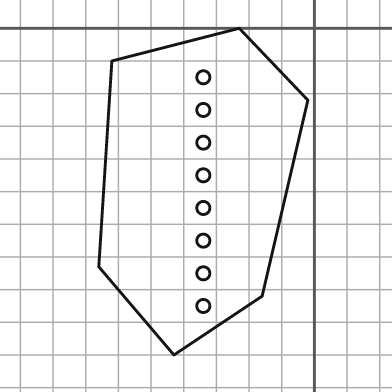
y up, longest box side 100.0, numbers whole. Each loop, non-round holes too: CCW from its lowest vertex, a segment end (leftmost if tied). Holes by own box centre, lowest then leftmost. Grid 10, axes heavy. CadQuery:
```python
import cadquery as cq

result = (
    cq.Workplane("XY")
    .moveTo(-43.0, -100.0)
    .lineTo(-16.0, -82.0)
    .lineTo(-2.0, -22.0)
    .lineTo(-23.0, 0.0)
    .lineTo(-62.0, -10.0)
    .lineTo(-66.0, -73.0)
    .close()
    .moveTo(-34.0, -85.0)
    .circle(2.0)
    .moveTo(-34.0, -75.0)
    .circle(2.0)
    .moveTo(-34.0, -65.0)
    .circle(2.0)
    .moveTo(-34.0, -55.0)
    .circle(2.0)
    .moveTo(-34.0, -45.0)
    .circle(2.0)
    .moveTo(-34.0, -35.0)
    .circle(2.0)
    .moveTo(-34.0, -25.0)
    .circle(2.0)
    .moveTo(-34.0, -15.0)
    .circle(2.0)
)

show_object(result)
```